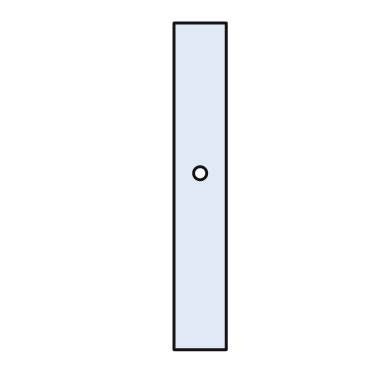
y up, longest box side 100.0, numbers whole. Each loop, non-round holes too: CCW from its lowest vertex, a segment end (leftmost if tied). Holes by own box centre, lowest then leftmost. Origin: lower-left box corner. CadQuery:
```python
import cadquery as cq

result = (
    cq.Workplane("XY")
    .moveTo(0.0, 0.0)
    .lineTo(16.0, 0.0)
    .lineTo(16.0, 100.0)
    .lineTo(0.0, 100.0)
    .close()
    .moveTo(8.0, 54.0)
    .circle(2.0)
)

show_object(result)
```